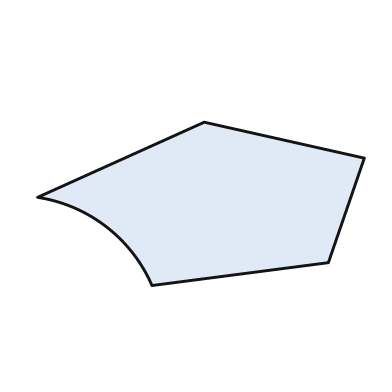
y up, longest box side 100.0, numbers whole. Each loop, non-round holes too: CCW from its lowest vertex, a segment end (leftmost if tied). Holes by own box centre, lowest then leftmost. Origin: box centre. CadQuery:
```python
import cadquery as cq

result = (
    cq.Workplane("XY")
    .moveTo(-15.0, -25.0)
    .lineTo(39.0, -18.0)
    .lineTo(50.0, 14.0)
    .lineTo(1.0, 25.0)
    .lineTo(-50.0, 2.0)
    .threePointArc((-29.0, -7.0), (-15.0, -25.0))
    .close()
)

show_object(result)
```